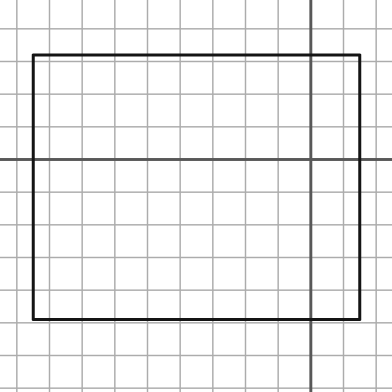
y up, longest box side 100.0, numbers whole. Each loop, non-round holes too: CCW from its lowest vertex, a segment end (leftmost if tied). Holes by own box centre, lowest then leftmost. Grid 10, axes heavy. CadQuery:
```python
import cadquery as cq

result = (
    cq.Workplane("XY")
    .moveTo(-85.0, -49.0)
    .lineTo(15.0, -49.0)
    .lineTo(15.0, 32.0)
    .lineTo(-85.0, 32.0)
    .close()
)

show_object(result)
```